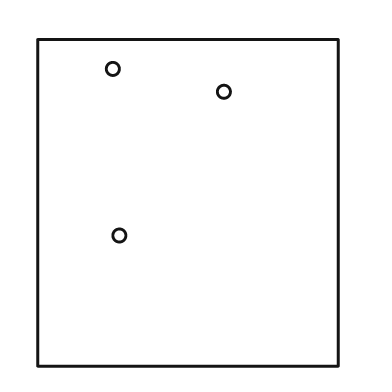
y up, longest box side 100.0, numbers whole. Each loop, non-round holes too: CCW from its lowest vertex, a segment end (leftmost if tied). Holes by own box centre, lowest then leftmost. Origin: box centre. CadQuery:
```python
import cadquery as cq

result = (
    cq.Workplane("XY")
    .moveTo(-46.0, -50.0)
    .lineTo(46.0, -50.0)
    .lineTo(46.0, 50.0)
    .lineTo(-46.0, 50.0)
    .close()
    .moveTo(-21.0, -10.0)
    .circle(2.0)
    .moveTo(11.0, 34.0)
    .circle(2.0)
    .moveTo(-23.0, 41.0)
    .circle(2.0)
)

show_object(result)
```